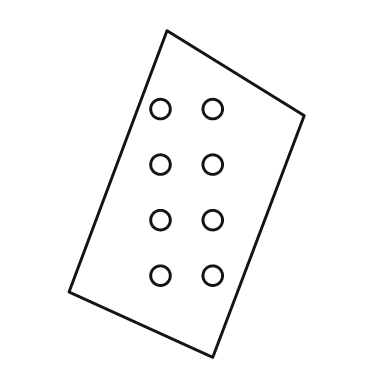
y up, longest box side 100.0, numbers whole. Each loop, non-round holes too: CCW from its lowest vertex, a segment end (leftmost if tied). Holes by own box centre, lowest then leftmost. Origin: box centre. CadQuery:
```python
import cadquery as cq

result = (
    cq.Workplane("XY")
    .moveTo(8.0, -50.0)
    .lineTo(36.0, 24.0)
    .lineTo(-6.0, 50.0)
    .lineTo(-36.0, -30.0)
    .close()
    .moveTo(-8.0, -25.0)
    .circle(3.0)
    .moveTo(8.0, -25.0)
    .circle(3.0)
    .moveTo(-8.0, -8.0)
    .circle(3.0)
    .moveTo(8.0, -8.0)
    .circle(3.0)
    .moveTo(-8.0, 9.0)
    .circle(3.0)
    .moveTo(8.0, 9.0)
    .circle(3.0)
    .moveTo(-8.0, 26.0)
    .circle(3.0)
    .moveTo(8.0, 26.0)
    .circle(3.0)
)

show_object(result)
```